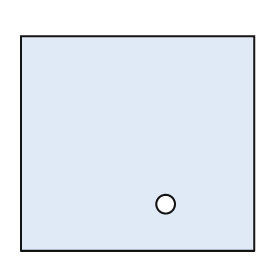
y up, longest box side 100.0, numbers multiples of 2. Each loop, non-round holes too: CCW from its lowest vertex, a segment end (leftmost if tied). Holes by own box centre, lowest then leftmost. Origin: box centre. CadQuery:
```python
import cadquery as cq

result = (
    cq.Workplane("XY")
    .moveTo(-50.0, -46.0)
    .lineTo(50.0, -46.0)
    .lineTo(50.0, 46.0)
    .lineTo(-50.0, 46.0)
    .close()
    .moveTo(12.0, -26.0)
    .circle(4.0)
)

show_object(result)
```